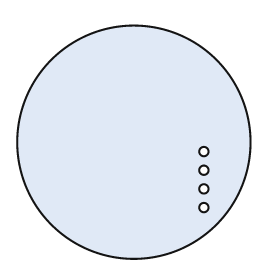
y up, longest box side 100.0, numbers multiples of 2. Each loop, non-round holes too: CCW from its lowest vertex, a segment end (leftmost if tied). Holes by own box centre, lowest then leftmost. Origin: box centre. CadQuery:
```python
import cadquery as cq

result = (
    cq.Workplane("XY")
    .moveTo(0.0, 0.0)
    .circle(50.0)
    .moveTo(30.0, -28.0)
    .circle(2.0)
    .moveTo(30.0, -20.0)
    .circle(2.0)
    .moveTo(30.0, -12.0)
    .circle(2.0)
    .moveTo(30.0, -4.0)
    .circle(2.0)
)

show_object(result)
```